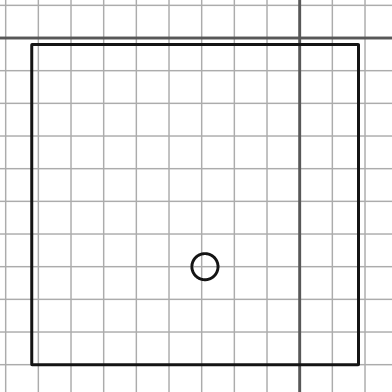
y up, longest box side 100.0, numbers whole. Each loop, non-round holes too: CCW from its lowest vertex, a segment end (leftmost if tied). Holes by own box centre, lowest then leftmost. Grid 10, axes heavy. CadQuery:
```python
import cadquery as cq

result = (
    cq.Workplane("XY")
    .moveTo(-82.0, -100.0)
    .lineTo(18.0, -100.0)
    .lineTo(18.0, -2.0)
    .lineTo(-82.0, -2.0)
    .close()
    .moveTo(-29.0, -70.0)
    .circle(4.0)
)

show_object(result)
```